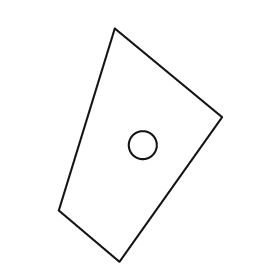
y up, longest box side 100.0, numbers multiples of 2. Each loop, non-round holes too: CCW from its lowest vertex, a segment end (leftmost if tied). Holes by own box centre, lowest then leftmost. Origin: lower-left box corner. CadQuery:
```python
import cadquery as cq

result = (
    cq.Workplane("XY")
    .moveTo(26.0, 0.0)
    .lineTo(70.0, 62.0)
    .lineTo(24.0, 100.0)
    .lineTo(0.0, 22.0)
    .close()
    .moveTo(36.0, 50.0)
    .circle(6.0)
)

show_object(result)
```